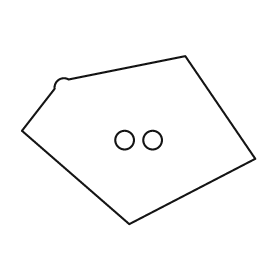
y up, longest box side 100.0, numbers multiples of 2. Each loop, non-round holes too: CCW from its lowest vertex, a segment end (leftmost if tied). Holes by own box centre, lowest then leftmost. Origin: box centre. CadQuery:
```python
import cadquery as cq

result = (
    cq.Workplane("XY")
    .moveTo(-4.0, -36.0)
    .lineTo(50.0, -8.0)
    .lineTo(20.0, 36.0)
    .lineTo(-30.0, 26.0)
    .threePointArc((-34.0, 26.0), (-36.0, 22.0))
    .lineTo(-50.0, 4.0)
    .close()
    .moveTo(-6.0, 0.0)
    .circle(4.0)
    .moveTo(6.0, 0.0)
    .circle(4.0)
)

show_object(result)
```